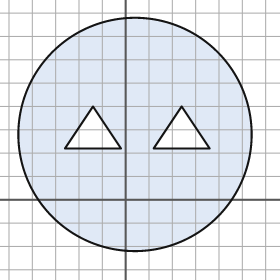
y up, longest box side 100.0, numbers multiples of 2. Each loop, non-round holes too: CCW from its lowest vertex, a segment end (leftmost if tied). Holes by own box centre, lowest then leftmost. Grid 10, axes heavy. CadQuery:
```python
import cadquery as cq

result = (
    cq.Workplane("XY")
    .moveTo(4.0, 28.0)
    .circle(50.0)
    .moveTo(-26.0, 22.0)
    .lineTo(-2.0, 22.0)
    .lineTo(-14.0, 40.0)
    .close()
    .moveTo(12.0, 22.0)
    .lineTo(36.0, 22.0)
    .lineTo(24.0, 40.0)
    .close()
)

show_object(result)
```